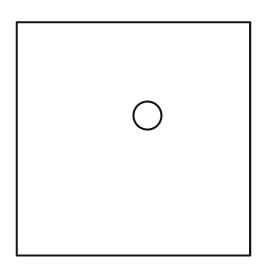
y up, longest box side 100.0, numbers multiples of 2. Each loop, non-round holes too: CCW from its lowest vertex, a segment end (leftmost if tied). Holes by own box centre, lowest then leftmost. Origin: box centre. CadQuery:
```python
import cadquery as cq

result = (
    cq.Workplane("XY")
    .moveTo(-50.0, -50.0)
    .lineTo(50.0, -50.0)
    .lineTo(50.0, 50.0)
    .lineTo(-50.0, 50.0)
    .close()
    .moveTo(6.0, 10.0)
    .circle(6.0)
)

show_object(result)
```